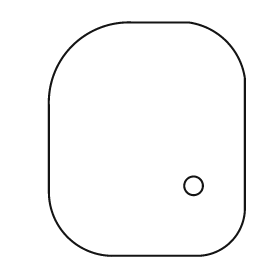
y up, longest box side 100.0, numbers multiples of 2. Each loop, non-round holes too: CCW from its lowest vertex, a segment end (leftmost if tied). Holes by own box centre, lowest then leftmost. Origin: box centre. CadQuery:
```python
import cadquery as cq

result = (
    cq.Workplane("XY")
    .moveTo(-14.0, -50.0)
    .lineTo(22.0, -50.0)
    .threePointArc((36.0, -44.0), (42.0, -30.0))
    .lineTo(42.0, 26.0)
    .threePointArc((34.0, 42.0), (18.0, 50.0))
    .lineTo(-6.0, 50.0)
    .threePointArc((-32.0, 40.0), (-42.0, 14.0))
    .lineTo(-42.0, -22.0)
    .threePointArc((-34.0, -42.0), (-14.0, -50.0))
    .close()
    .moveTo(20.0, -20.0)
    .circle(4.0)
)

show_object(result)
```